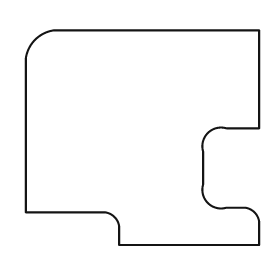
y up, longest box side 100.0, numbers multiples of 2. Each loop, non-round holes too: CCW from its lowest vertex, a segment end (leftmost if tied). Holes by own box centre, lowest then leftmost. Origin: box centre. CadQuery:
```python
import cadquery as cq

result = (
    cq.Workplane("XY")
    .moveTo(-10.0, -46.0)
    .lineTo(50.0, -46.0)
    .lineTo(50.0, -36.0)
    .threePointArc((48.0, -32.0), (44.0, -30.0))
    .lineTo(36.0, -30.0)
    .threePointArc((28.0, -28.0), (26.0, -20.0))
    .lineTo(26.0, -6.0)
    .threePointArc((28.0, 2.0), (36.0, 4.0))
    .lineTo(50.0, 4.0)
    .lineTo(50.0, 46.0)
    .lineTo(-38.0, 46.0)
    .threePointArc((-46.0, 42.0), (-50.0, 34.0))
    .lineTo(-50.0, -32.0)
    .lineTo(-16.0, -32.0)
    .threePointArc((-12.0, -34.0), (-10.0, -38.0))
    .close()
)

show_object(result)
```